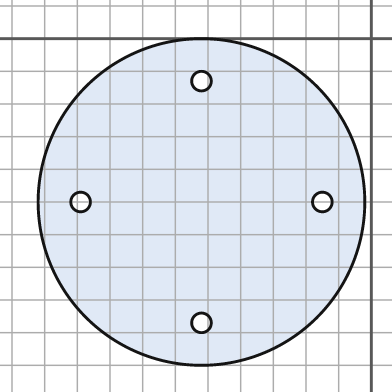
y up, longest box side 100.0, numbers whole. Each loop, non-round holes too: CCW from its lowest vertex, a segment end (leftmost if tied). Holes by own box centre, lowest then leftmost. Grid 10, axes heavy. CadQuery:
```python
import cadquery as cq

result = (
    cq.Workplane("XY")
    .moveTo(-52.0, -50.0)
    .circle(50.0)
    .moveTo(-52.0, -87.0)
    .circle(3.0)
    .moveTo(-89.0, -50.0)
    .circle(3.0)
    .moveTo(-15.0, -50.0)
    .circle(3.0)
    .moveTo(-52.0, -13.0)
    .circle(3.0)
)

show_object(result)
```